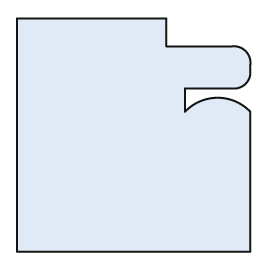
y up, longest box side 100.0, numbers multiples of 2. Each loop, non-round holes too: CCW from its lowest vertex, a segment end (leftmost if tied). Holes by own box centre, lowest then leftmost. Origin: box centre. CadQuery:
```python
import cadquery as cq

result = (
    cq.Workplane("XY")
    .moveTo(-50.0, -50.0)
    .lineTo(50.0, -50.0)
    .lineTo(50.0, 10.0)
    .threePointArc((36.0, 16.0), (22.0, 10.0))
    .lineTo(22.0, 20.0)
    .lineTo(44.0, 20.0)
    .threePointArc((48.0, 22.0), (50.0, 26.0))
    .lineTo(50.0, 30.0)
    .threePointArc((48.0, 36.0), (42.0, 38.0))
    .lineTo(14.0, 38.0)
    .lineTo(14.0, 50.0)
    .lineTo(-50.0, 50.0)
    .close()
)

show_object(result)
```